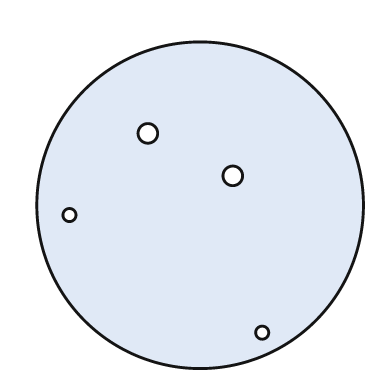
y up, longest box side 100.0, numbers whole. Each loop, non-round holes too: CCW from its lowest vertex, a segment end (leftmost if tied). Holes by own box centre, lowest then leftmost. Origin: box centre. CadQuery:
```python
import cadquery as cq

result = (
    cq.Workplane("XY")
    .moveTo(0.0, 0.0)
    .circle(50.0)
    .moveTo(19.0, -39.0)
    .circle(2.0)
    .moveTo(-40.0, -3.0)
    .circle(2.0)
    .moveTo(10.0, 9.0)
    .circle(3.0)
    .moveTo(-16.0, 22.0)
    .circle(3.0)
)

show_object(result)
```